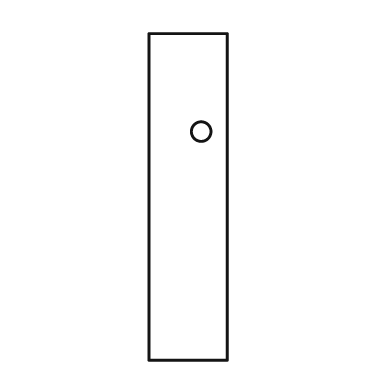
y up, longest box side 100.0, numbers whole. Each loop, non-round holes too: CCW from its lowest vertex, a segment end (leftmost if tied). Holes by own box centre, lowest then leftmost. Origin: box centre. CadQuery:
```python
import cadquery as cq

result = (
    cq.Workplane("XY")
    .moveTo(-12.0, -50.0)
    .lineTo(12.0, -50.0)
    .lineTo(12.0, 50.0)
    .lineTo(-12.0, 50.0)
    .close()
    .moveTo(4.0, 20.0)
    .circle(3.0)
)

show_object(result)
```